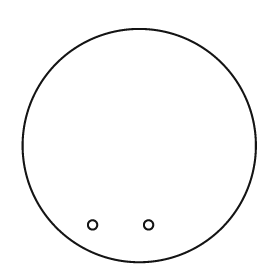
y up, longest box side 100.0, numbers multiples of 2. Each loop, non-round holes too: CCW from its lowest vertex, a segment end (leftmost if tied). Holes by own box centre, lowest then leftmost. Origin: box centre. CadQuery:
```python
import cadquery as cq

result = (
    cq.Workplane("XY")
    .moveTo(0.0, 0.0)
    .circle(50.0)
    .moveTo(-20.0, -34.0)
    .circle(2.0)
    .moveTo(4.0, -34.0)
    .circle(2.0)
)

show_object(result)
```